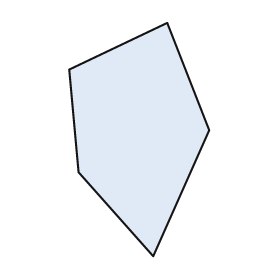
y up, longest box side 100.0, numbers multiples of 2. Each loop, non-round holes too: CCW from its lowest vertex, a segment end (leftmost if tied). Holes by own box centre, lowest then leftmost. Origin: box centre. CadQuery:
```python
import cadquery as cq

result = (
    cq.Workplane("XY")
    .moveTo(6.0, -50.0)
    .lineTo(30.0, 4.0)
    .lineTo(12.0, 50.0)
    .lineTo(-30.0, 30.0)
    .lineTo(-26.0, -14.0)
    .close()
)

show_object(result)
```